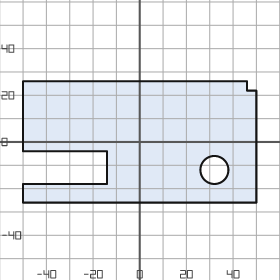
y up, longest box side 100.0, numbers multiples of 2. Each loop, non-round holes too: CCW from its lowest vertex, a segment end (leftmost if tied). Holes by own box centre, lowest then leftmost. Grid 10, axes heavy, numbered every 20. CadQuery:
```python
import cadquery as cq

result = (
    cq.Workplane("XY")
    .moveTo(-50.0, -26.0)
    .lineTo(50.0, -26.0)
    .lineTo(50.0, 22.0)
    .lineTo(46.0, 22.0)
    .lineTo(46.0, 26.0)
    .lineTo(-50.0, 26.0)
    .lineTo(-50.0, -4.0)
    .lineTo(-14.0, -4.0)
    .lineTo(-14.0, -18.0)
    .lineTo(-50.0, -18.0)
    .close()
    .moveTo(32.0, -12.0)
    .circle(6.0)
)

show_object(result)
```